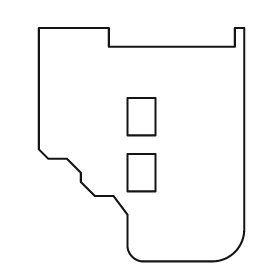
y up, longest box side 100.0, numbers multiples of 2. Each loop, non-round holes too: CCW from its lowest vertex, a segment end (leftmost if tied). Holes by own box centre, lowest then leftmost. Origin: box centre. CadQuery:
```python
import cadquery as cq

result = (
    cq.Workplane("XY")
    .moveTo(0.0, -50.0)
    .lineTo(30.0, -50.0)
    .threePointArc((40.0, -46.0), (44.0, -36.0))
    .lineTo(44.0, 50.0)
    .lineTo(40.0, 50.0)
    .lineTo(40.0, 42.0)
    .lineTo(-14.0, 42.0)
    .lineTo(-14.0, 50.0)
    .lineTo(-44.0, 50.0)
    .lineTo(-44.0, -2.0)
    .lineTo(-40.0, -6.0)
    .lineTo(-32.0, -6.0)
    .lineTo(-26.0, -12.0)
    .lineTo(-26.0, -16.0)
    .lineTo(-20.0, -22.0)
    .lineTo(-12.0, -22.0)
    .lineTo(-6.0, -30.0)
    .lineTo(-6.0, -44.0)
    .threePointArc((-4.0, -48.0), (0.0, -50.0))
    .close()
    .moveTo(-6.0, -20.0)
    .lineTo(6.0, -20.0)
    .lineTo(6.0, -4.0)
    .lineTo(-6.0, -4.0)
    .close()
    .moveTo(-6.0, 4.0)
    .lineTo(6.0, 4.0)
    .lineTo(6.0, 20.0)
    .lineTo(-6.0, 20.0)
    .close()
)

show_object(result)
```